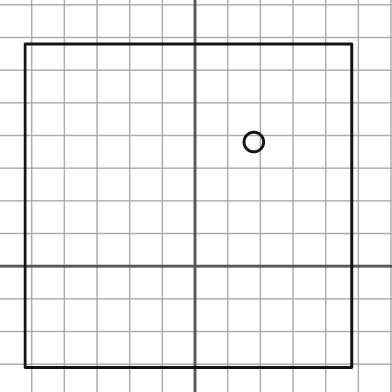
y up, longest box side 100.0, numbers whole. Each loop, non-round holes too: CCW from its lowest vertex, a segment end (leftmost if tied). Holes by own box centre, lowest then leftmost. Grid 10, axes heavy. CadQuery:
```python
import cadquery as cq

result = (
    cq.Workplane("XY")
    .moveTo(-52.0, -31.0)
    .lineTo(48.0, -31.0)
    .lineTo(48.0, 68.0)
    .lineTo(-52.0, 68.0)
    .close()
    .moveTo(18.0, 38.0)
    .circle(3.0)
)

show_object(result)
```